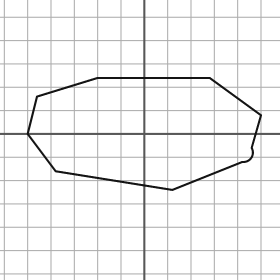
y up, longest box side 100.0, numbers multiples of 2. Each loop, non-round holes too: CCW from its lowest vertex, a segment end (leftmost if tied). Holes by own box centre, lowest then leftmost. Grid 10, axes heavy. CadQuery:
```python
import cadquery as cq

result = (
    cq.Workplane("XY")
    .moveTo(12.0, -24.0)
    .lineTo(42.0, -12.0)
    .threePointArc((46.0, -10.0), (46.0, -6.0))
    .lineTo(50.0, 8.0)
    .lineTo(28.0, 24.0)
    .lineTo(-20.0, 24.0)
    .lineTo(-46.0, 16.0)
    .lineTo(-50.0, 0.0)
    .lineTo(-38.0, -16.0)
    .close()
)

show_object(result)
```